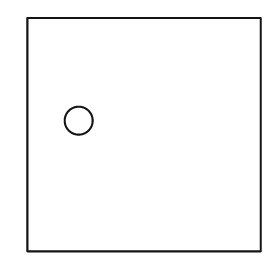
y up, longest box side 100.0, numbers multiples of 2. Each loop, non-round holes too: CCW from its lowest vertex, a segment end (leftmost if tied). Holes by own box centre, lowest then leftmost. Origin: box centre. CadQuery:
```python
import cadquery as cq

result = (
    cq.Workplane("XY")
    .moveTo(-50.0, -50.0)
    .lineTo(50.0, -50.0)
    .lineTo(50.0, 50.0)
    .lineTo(-50.0, 50.0)
    .close()
    .moveTo(-28.0, 6.0)
    .circle(6.0)
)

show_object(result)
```